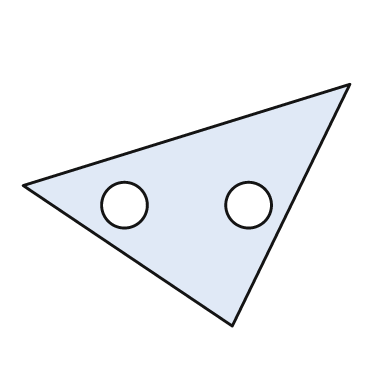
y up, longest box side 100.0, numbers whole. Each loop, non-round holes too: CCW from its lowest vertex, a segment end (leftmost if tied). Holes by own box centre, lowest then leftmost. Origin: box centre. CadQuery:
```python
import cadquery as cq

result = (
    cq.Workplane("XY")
    .moveTo(14.0, -37.0)
    .lineTo(50.0, 37.0)
    .lineTo(-50.0, 6.0)
    .close()
    .moveTo(-19.0, 0.0)
    .circle(7.0)
    .moveTo(19.0, 0.0)
    .circle(7.0)
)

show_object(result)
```